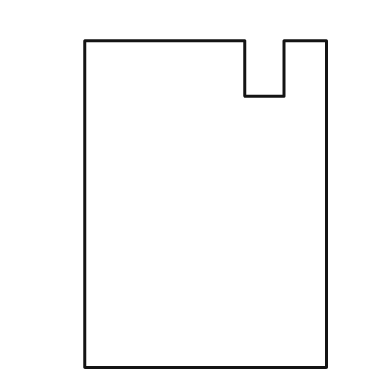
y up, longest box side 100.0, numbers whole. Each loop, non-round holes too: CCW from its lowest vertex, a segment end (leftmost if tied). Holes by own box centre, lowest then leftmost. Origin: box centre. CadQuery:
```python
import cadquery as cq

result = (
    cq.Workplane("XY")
    .moveTo(-37.0, -50.0)
    .lineTo(37.0, -50.0)
    .lineTo(37.0, 50.0)
    .lineTo(24.0, 50.0)
    .lineTo(24.0, 33.0)
    .lineTo(12.0, 33.0)
    .lineTo(12.0, 50.0)
    .lineTo(-37.0, 50.0)
    .close()
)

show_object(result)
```